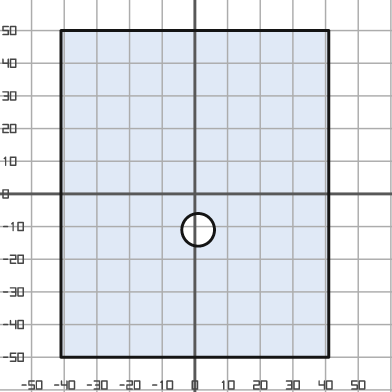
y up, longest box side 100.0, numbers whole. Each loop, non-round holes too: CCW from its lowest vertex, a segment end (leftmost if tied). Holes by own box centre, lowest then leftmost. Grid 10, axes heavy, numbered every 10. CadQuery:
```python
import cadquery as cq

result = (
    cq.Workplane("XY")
    .moveTo(-41.0, -50.0)
    .lineTo(41.0, -50.0)
    .lineTo(41.0, 50.0)
    .lineTo(-41.0, 50.0)
    .close()
    .moveTo(1.0, -11.0)
    .circle(5.0)
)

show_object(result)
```